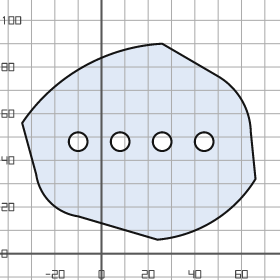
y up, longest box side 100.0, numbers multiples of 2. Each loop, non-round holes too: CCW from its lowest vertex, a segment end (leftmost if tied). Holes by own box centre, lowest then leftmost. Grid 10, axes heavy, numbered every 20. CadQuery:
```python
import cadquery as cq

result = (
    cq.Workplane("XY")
    .moveTo(24.0, 6.0)
    .threePointArc((48.0, 14.0), (66.0, 32.0))
    .lineTo(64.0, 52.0)
    .threePointArc((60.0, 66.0), (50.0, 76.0))
    .lineTo(26.0, 90.0)
    .threePointArc((-8.0, 80.0), (-34.0, 56.0))
    .lineTo(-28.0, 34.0)
    .threePointArc((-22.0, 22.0), (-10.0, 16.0))
    .close()
    .moveTo(-10.0, 48.0)
    .circle(4.0)
    .moveTo(8.0, 48.0)
    .circle(4.0)
    .moveTo(26.0, 48.0)
    .circle(4.0)
    .moveTo(44.0, 48.0)
    .circle(4.0)
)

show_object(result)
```